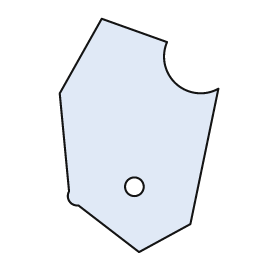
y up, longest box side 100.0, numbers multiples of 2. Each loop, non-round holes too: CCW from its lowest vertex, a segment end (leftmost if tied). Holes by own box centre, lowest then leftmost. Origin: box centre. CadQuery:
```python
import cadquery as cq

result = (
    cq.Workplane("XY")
    .moveTo(0.0, -50.0)
    .lineTo(22.0, -38.0)
    .lineTo(34.0, 20.0)
    .threePointArc((16.0, 22.0), (12.0, 40.0))
    .lineTo(-16.0, 50.0)
    .lineTo(-34.0, 18.0)
    .lineTo(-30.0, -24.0)
    .threePointArc((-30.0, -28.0), (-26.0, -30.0))
    .close()
    .moveTo(-2.0, -22.0)
    .circle(4.0)
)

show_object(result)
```